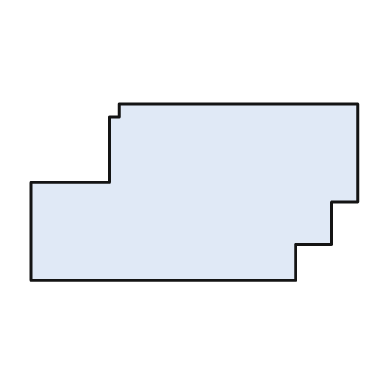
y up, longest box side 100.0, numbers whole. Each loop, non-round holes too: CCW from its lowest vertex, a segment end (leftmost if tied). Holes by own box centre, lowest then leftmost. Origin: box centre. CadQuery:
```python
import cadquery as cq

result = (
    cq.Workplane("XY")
    .moveTo(-50.0, -27.0)
    .lineTo(31.0, -27.0)
    .lineTo(31.0, -16.0)
    .lineTo(42.0, -16.0)
    .lineTo(42.0, -3.0)
    .lineTo(50.0, -3.0)
    .lineTo(50.0, 27.0)
    .lineTo(-23.0, 27.0)
    .lineTo(-23.0, 23.0)
    .lineTo(-26.0, 23.0)
    .lineTo(-26.0, 3.0)
    .lineTo(-50.0, 3.0)
    .close()
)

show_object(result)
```